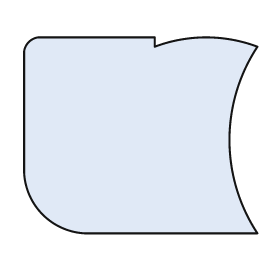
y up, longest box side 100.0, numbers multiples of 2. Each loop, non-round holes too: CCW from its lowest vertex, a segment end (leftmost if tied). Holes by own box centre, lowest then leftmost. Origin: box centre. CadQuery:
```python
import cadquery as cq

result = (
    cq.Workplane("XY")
    .moveTo(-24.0, -42.0)
    .lineTo(50.0, -42.0)
    .threePointArc((38.0, -2.0), (50.0, 38.0))
    .threePointArc((28.0, 42.0), (6.0, 38.0))
    .lineTo(6.0, 42.0)
    .lineTo(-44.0, 42.0)
    .threePointArc((-48.0, 40.0), (-50.0, 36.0))
    .lineTo(-50.0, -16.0)
    .threePointArc((-42.0, -34.0), (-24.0, -42.0))
    .close()
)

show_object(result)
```